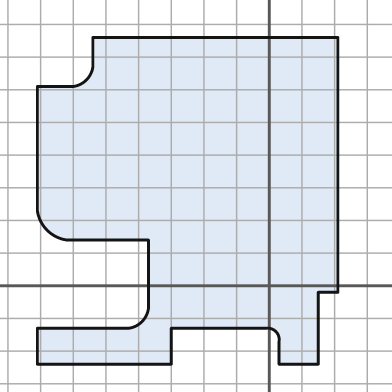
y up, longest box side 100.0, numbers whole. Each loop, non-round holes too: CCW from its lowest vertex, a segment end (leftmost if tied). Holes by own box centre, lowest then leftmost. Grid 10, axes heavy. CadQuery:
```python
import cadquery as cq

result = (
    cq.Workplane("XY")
    .moveTo(-71.0, -24.0)
    .lineTo(-30.0, -24.0)
    .lineTo(-30.0, -13.0)
    .lineTo(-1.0, -13.0)
    .threePointArc((2.0, -14.0), (3.0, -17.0))
    .lineTo(3.0, -24.0)
    .lineTo(15.0, -24.0)
    .lineTo(15.0, -2.0)
    .lineTo(21.0, -2.0)
    .lineTo(21.0, 76.0)
    .lineTo(-54.0, 76.0)
    .lineTo(-54.0, 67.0)
    .threePointArc((-56.0, 63.0), (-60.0, 61.0))
    .lineTo(-71.0, 61.0)
    .lineTo(-71.0, 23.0)
    .threePointArc((-68.0, 17.0), (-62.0, 14.0))
    .lineTo(-37.0, 14.0)
    .lineTo(-37.0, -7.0)
    .threePointArc((-39.0, -11.0), (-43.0, -13.0))
    .lineTo(-71.0, -13.0)
    .close()
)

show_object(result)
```